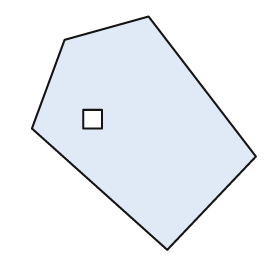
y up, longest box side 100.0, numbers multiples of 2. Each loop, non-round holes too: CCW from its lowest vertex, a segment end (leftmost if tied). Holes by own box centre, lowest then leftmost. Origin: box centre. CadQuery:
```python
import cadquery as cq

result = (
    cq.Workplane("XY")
    .moveTo(10.0, -50.0)
    .lineTo(48.0, -10.0)
    .lineTo(2.0, 50.0)
    .lineTo(-34.0, 40.0)
    .lineTo(-48.0, 2.0)
    .close()
    .moveTo(-26.0, 2.0)
    .lineTo(-18.0, 2.0)
    .lineTo(-18.0, 10.0)
    .lineTo(-26.0, 10.0)
    .close()
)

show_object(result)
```